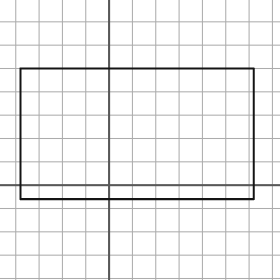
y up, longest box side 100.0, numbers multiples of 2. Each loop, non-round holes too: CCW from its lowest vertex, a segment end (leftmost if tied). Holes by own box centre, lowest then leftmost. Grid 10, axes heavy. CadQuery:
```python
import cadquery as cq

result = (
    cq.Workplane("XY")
    .moveTo(-38.0, -6.0)
    .lineTo(62.0, -6.0)
    .lineTo(62.0, 50.0)
    .lineTo(-38.0, 50.0)
    .close()
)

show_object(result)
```